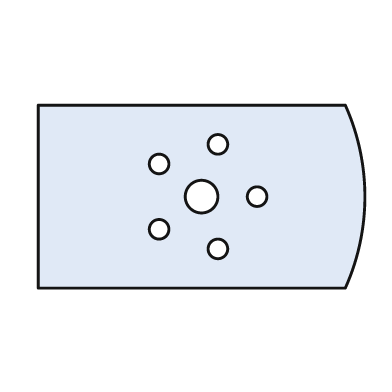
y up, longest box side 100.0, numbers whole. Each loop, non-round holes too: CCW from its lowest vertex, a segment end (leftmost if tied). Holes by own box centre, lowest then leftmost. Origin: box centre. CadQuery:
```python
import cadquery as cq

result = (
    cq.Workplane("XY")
    .moveTo(-50.0, -28.0)
    .lineTo(44.0, -28.0)
    .threePointArc((50.0, 0.0), (44.0, 28.0))
    .lineTo(-50.0, 28.0)
    .close()
    .moveTo(5.0, -16.0)
    .circle(3.0)
    .moveTo(-13.0, -10.0)
    .circle(3.0)
    .moveTo(0.0, 0.0)
    .circle(5.0)
    .moveTo(17.0, 0.0)
    .circle(3.0)
    .moveTo(-13.0, 10.0)
    .circle(3.0)
    .moveTo(5.0, 16.0)
    .circle(3.0)
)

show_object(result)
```